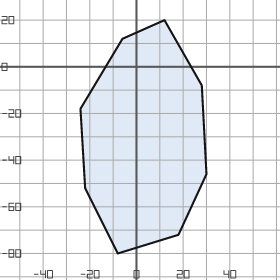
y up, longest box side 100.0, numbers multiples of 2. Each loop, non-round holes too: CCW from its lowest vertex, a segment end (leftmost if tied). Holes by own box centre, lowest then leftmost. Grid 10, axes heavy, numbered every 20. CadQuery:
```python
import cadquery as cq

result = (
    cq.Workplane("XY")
    .moveTo(-8.0, -80.0)
    .lineTo(18.0, -72.0)
    .lineTo(30.0, -46.0)
    .lineTo(28.0, -8.0)
    .lineTo(12.0, 20.0)
    .lineTo(-6.0, 12.0)
    .lineTo(-24.0, -18.0)
    .lineTo(-22.0, -52.0)
    .close()
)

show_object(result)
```